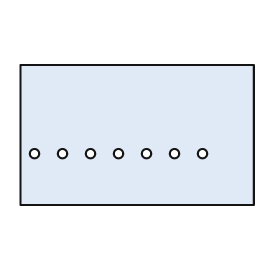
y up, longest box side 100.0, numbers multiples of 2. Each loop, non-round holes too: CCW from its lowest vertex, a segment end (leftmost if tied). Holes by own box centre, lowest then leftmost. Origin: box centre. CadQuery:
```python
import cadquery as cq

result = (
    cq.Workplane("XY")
    .moveTo(-50.0, -30.0)
    .lineTo(50.0, -30.0)
    .lineTo(50.0, 30.0)
    .lineTo(-50.0, 30.0)
    .close()
    .moveTo(-44.0, -8.0)
    .circle(2.0)
    .moveTo(-32.0, -8.0)
    .circle(2.0)
    .moveTo(-20.0, -8.0)
    .circle(2.0)
    .moveTo(-8.0, -8.0)
    .circle(2.0)
    .moveTo(4.0, -8.0)
    .circle(2.0)
    .moveTo(16.0, -8.0)
    .circle(2.0)
    .moveTo(28.0, -8.0)
    .circle(2.0)
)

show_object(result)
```